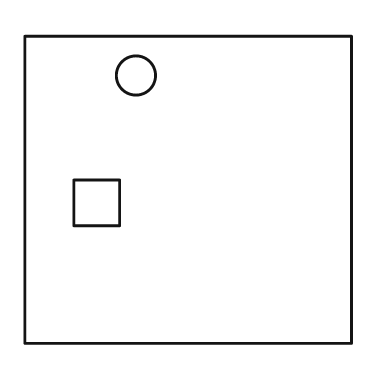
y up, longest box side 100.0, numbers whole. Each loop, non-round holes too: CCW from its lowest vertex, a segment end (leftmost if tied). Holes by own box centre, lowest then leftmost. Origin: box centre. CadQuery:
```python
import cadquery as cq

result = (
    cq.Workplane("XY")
    .moveTo(-50.0, -47.0)
    .lineTo(50.0, -47.0)
    .lineTo(50.0, 47.0)
    .lineTo(-50.0, 47.0)
    .close()
    .moveTo(-35.0, -11.0)
    .lineTo(-21.0, -11.0)
    .lineTo(-21.0, 3.0)
    .lineTo(-35.0, 3.0)
    .close()
    .moveTo(-16.0, 35.0)
    .circle(6.0)
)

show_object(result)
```